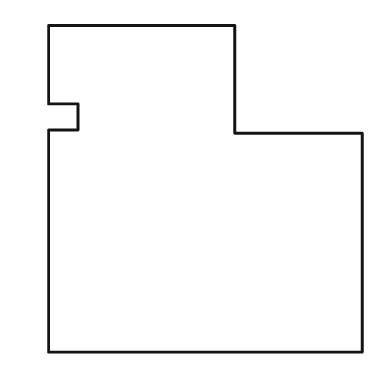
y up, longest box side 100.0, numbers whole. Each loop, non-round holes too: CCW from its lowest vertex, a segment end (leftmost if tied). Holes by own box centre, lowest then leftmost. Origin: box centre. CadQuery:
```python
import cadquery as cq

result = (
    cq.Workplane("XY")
    .moveTo(-48.0, -50.0)
    .lineTo(48.0, -50.0)
    .lineTo(48.0, 17.0)
    .lineTo(9.0, 17.0)
    .lineTo(9.0, 50.0)
    .lineTo(-48.0, 50.0)
    .lineTo(-48.0, 26.0)
    .lineTo(-39.0, 26.0)
    .lineTo(-39.0, 18.0)
    .lineTo(-48.0, 18.0)
    .close()
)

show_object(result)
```